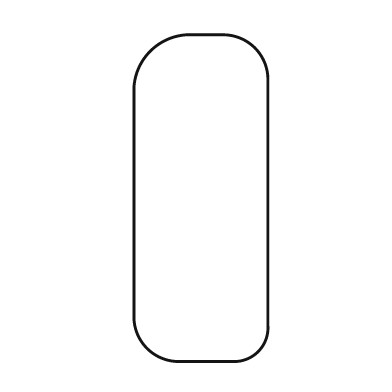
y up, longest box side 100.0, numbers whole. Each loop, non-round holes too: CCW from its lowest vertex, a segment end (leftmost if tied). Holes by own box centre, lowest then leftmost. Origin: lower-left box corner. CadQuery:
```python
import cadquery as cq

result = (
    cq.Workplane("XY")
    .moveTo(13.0, 0.0)
    .lineTo(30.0, 0.0)
    .threePointArc((38.0, 3.0), (41.0, 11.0))
    .lineTo(41.0, 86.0)
    .threePointArc((37.0, 96.0), (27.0, 100.0))
    .lineTo(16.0, 100.0)
    .threePointArc((5.0, 95.0), (0.0, 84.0))
    .lineTo(0.0, 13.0)
    .threePointArc((4.0, 4.0), (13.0, 0.0))
    .close()
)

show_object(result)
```